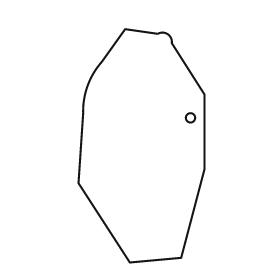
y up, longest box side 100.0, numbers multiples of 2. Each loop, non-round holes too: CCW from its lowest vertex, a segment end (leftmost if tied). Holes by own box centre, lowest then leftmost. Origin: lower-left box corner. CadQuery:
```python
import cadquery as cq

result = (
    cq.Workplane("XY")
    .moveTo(22.0, 0.0)
    .lineTo(44.0, 2.0)
    .lineTo(54.0, 40.0)
    .lineTo(54.0, 72.0)
    .lineTo(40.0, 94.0)
    .threePointArc((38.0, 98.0), (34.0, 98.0))
    .lineTo(20.0, 100.0)
    .lineTo(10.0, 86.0)
    .threePointArc((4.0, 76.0), (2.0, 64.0))
    .lineTo(0.0, 34.0)
    .close()
    .moveTo(48.0, 62.0)
    .circle(2.0)
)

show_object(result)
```